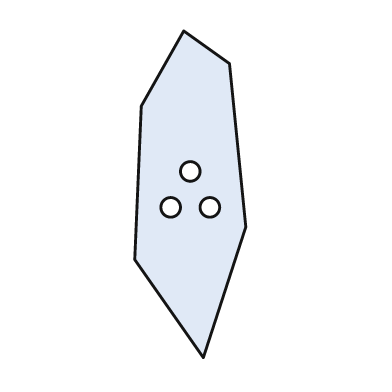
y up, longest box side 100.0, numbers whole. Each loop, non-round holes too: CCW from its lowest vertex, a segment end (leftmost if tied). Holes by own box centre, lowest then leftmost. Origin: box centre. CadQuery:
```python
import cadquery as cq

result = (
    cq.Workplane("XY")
    .moveTo(4.0, -50.0)
    .lineTo(17.0, -10.0)
    .lineTo(12.0, 40.0)
    .lineTo(-2.0, 50.0)
    .lineTo(-15.0, 27.0)
    .lineTo(-17.0, -20.0)
    .close()
    .moveTo(-6.0, -4.0)
    .circle(3.0)
    .moveTo(6.0, -4.0)
    .circle(3.0)
    .moveTo(0.0, 7.0)
    .circle(3.0)
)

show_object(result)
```